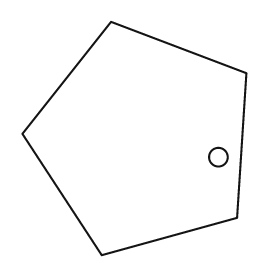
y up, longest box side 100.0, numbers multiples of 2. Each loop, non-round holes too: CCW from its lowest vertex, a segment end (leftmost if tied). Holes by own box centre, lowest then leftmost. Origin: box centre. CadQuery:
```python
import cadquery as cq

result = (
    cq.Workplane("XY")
    .moveTo(-14.0, -50.0)
    .lineTo(44.0, -34.0)
    .lineTo(48.0, 28.0)
    .lineTo(-10.0, 50.0)
    .lineTo(-48.0, 2.0)
    .close()
    .moveTo(36.0, -8.0)
    .circle(4.0)
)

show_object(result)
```